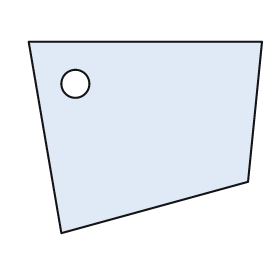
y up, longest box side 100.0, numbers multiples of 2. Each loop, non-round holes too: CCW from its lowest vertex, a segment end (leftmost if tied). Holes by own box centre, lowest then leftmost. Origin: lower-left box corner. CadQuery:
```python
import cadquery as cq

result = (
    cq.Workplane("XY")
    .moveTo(14.0, 0.0)
    .lineTo(94.0, 22.0)
    .lineTo(100.0, 82.0)
    .lineTo(0.0, 82.0)
    .close()
    .moveTo(20.0, 64.0)
    .circle(6.0)
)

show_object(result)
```